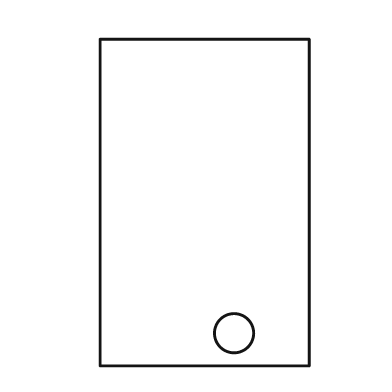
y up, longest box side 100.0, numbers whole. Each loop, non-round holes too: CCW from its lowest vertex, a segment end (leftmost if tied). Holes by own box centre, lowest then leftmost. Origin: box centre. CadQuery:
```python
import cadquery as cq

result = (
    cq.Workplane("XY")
    .moveTo(-32.0, -50.0)
    .lineTo(32.0, -50.0)
    .lineTo(32.0, 50.0)
    .lineTo(-32.0, 50.0)
    .close()
    .moveTo(9.0, -40.0)
    .circle(6.0)
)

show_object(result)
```